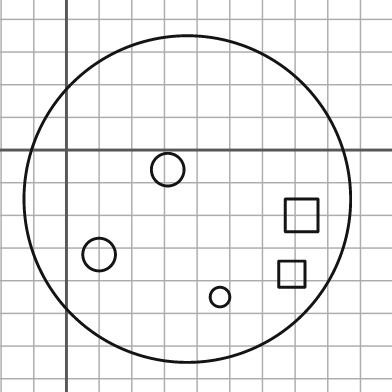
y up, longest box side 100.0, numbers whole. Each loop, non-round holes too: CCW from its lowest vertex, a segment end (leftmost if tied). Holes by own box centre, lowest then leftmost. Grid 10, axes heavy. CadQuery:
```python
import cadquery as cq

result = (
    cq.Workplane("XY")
    .moveTo(37.0, -15.0)
    .circle(50.0)
    .moveTo(47.0, -45.0)
    .circle(3.0)
    .moveTo(65.0, -42.0)
    .lineTo(73.0, -42.0)
    .lineTo(73.0, -34.0)
    .lineTo(65.0, -34.0)
    .close()
    .moveTo(10.0, -32.0)
    .circle(5.0)
    .moveTo(67.0, -25.0)
    .lineTo(77.0, -25.0)
    .lineTo(77.0, -15.0)
    .lineTo(67.0, -15.0)
    .close()
    .moveTo(31.0, -6.0)
    .circle(5.0)
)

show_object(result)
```